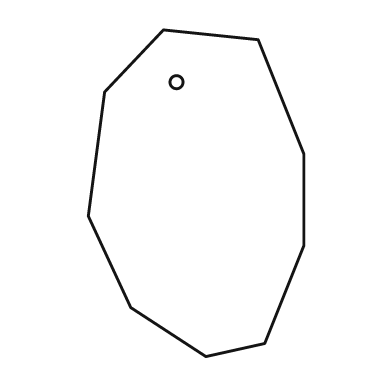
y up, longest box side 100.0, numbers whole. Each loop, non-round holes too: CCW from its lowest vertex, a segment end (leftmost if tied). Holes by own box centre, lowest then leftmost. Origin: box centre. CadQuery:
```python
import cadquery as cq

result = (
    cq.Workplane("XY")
    .moveTo(3.0, -50.0)
    .lineTo(21.0, -46.0)
    .lineTo(33.0, -16.0)
    .lineTo(33.0, 12.0)
    .lineTo(19.0, 47.0)
    .lineTo(-10.0, 50.0)
    .lineTo(-28.0, 31.0)
    .lineTo(-33.0, -7.0)
    .lineTo(-20.0, -35.0)
    .close()
    .moveTo(-6.0, 34.0)
    .circle(2.0)
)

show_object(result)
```